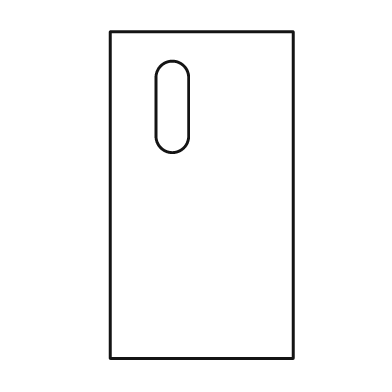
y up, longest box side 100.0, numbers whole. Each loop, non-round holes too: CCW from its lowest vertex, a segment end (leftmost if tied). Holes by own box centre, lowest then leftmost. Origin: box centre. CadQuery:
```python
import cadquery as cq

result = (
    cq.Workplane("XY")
    .moveTo(-28.0, -50.0)
    .lineTo(28.0, -50.0)
    .lineTo(28.0, 50.0)
    .lineTo(-28.0, 50.0)
    .close()
    .moveTo(-14.0, 18.0)
    .threePointArc((-9.0, 13.0), (-4.0, 18.0))
    .lineTo(-4.0, 36.0)
    .threePointArc((-9.0, 41.0), (-14.0, 36.0))
    .close()
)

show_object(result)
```